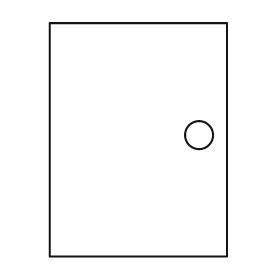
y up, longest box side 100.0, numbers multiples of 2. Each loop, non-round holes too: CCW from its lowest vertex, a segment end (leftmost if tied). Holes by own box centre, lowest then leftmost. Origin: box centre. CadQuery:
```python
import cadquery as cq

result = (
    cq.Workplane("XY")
    .moveTo(-38.0, -50.0)
    .lineTo(38.0, -50.0)
    .lineTo(38.0, 50.0)
    .lineTo(-38.0, 50.0)
    .close()
    .moveTo(26.0, 2.0)
    .circle(6.0)
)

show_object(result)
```